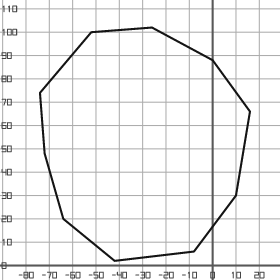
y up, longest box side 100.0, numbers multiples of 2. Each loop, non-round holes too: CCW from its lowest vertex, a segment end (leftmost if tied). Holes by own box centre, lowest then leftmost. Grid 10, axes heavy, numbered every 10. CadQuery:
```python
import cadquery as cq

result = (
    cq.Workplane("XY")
    .moveTo(-42.0, 2.0)
    .lineTo(-8.0, 6.0)
    .lineTo(10.0, 30.0)
    .lineTo(16.0, 66.0)
    .lineTo(0.0, 88.0)
    .lineTo(-26.0, 102.0)
    .lineTo(-52.0, 100.0)
    .lineTo(-74.0, 74.0)
    .lineTo(-72.0, 48.0)
    .lineTo(-64.0, 20.0)
    .close()
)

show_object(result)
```